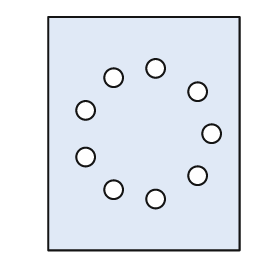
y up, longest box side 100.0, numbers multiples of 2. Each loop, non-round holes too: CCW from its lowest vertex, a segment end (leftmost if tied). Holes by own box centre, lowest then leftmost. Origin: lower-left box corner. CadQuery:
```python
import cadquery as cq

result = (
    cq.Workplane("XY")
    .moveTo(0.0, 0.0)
    .lineTo(82.0, 0.0)
    .lineTo(82.0, 100.0)
    .lineTo(0.0, 100.0)
    .close()
    .moveTo(46.0, 22.0)
    .circle(4.0)
    .moveTo(28.0, 26.0)
    .circle(4.0)
    .moveTo(64.0, 32.0)
    .circle(4.0)
    .moveTo(16.0, 40.0)
    .circle(4.0)
    .moveTo(70.0, 50.0)
    .circle(4.0)
    .moveTo(16.0, 60.0)
    .circle(4.0)
    .moveTo(64.0, 68.0)
    .circle(4.0)
    .moveTo(28.0, 74.0)
    .circle(4.0)
    .moveTo(46.0, 78.0)
    .circle(4.0)
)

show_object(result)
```